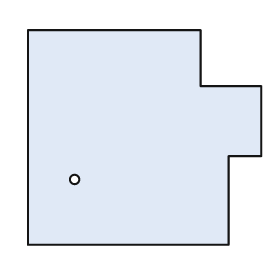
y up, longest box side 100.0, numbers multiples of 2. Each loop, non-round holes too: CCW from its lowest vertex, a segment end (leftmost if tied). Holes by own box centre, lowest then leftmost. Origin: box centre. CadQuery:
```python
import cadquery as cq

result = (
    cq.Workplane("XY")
    .moveTo(-50.0, -46.0)
    .lineTo(36.0, -46.0)
    .lineTo(36.0, -8.0)
    .lineTo(50.0, -8.0)
    .lineTo(50.0, 22.0)
    .lineTo(24.0, 22.0)
    .lineTo(24.0, 46.0)
    .lineTo(-50.0, 46.0)
    .close()
    .moveTo(-30.0, -18.0)
    .circle(2.0)
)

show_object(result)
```